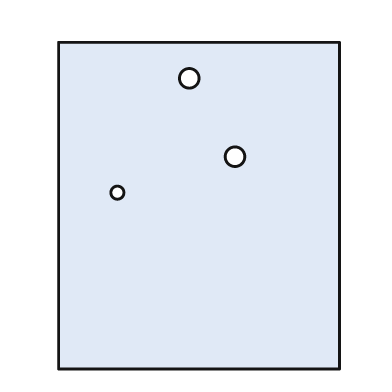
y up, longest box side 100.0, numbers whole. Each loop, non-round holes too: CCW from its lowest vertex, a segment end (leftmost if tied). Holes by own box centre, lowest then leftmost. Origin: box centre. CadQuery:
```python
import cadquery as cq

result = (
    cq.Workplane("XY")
    .moveTo(-43.0, -50.0)
    .lineTo(43.0, -50.0)
    .lineTo(43.0, 50.0)
    .lineTo(-43.0, 50.0)
    .close()
    .moveTo(-25.0, 4.0)
    .circle(2.0)
    .moveTo(11.0, 15.0)
    .circle(3.0)
    .moveTo(-3.0, 39.0)
    .circle(3.0)
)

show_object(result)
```